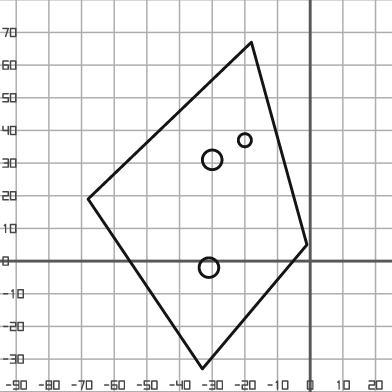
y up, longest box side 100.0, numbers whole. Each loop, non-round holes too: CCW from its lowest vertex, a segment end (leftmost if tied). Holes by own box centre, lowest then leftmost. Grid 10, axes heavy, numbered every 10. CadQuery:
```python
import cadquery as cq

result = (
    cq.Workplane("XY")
    .moveTo(-33.0, -33.0)
    .lineTo(-1.0, 5.0)
    .lineTo(-18.0, 67.0)
    .lineTo(-68.0, 19.0)
    .close()
    .moveTo(-31.0, -2.0)
    .circle(3.0)
    .moveTo(-30.0, 31.0)
    .circle(3.0)
    .moveTo(-20.0, 37.0)
    .circle(2.0)
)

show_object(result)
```